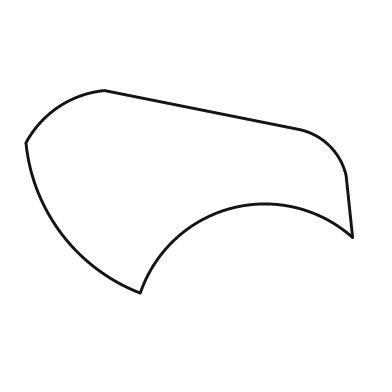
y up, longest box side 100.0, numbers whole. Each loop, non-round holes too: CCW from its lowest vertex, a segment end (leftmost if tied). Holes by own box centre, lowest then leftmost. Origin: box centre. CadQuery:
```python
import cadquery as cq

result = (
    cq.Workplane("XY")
    .moveTo(-15.0, -31.0)
    .threePointArc((13.0, -5.0), (50.0, -14.0))
    .lineTo(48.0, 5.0)
    .threePointArc((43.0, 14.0), (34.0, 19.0))
    .lineTo(-26.0, 31.0)
    .threePointArc((-40.0, 26.0), (-50.0, 15.0))
    .threePointArc((-39.0, -13.0), (-15.0, -31.0))
    .close()
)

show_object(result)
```